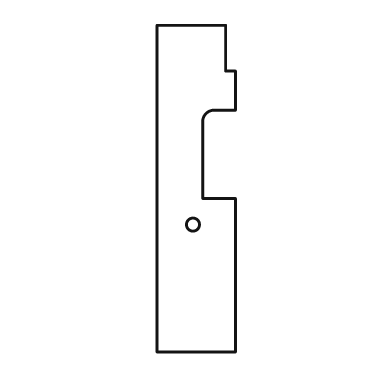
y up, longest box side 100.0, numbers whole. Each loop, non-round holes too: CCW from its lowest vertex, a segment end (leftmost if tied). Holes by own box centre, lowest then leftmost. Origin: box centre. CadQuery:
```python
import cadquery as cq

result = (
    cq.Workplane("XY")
    .moveTo(-12.0, -50.0)
    .lineTo(12.0, -50.0)
    .lineTo(12.0, -3.0)
    .lineTo(2.0, -3.0)
    .lineTo(2.0, 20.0)
    .threePointArc((3.0, 23.0), (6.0, 24.0))
    .lineTo(12.0, 24.0)
    .lineTo(12.0, 36.0)
    .lineTo(9.0, 36.0)
    .lineTo(9.0, 50.0)
    .lineTo(-12.0, 50.0)
    .close()
    .moveTo(-1.0, -11.0)
    .circle(2.0)
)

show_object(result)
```